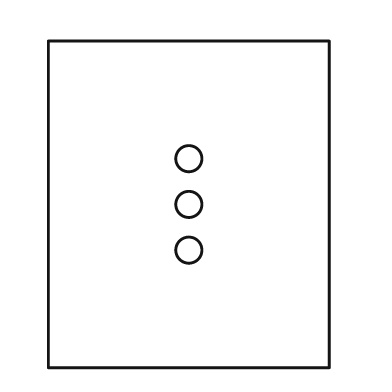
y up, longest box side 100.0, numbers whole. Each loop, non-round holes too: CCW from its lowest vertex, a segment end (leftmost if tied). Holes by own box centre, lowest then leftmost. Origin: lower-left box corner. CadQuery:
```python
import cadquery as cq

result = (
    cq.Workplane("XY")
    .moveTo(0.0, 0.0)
    .lineTo(86.0, 0.0)
    .lineTo(86.0, 100.0)
    .lineTo(0.0, 100.0)
    .close()
    .moveTo(43.0, 36.0)
    .circle(4.0)
    .moveTo(43.0, 50.0)
    .circle(4.0)
    .moveTo(43.0, 64.0)
    .circle(4.0)
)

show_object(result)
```